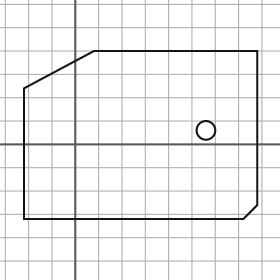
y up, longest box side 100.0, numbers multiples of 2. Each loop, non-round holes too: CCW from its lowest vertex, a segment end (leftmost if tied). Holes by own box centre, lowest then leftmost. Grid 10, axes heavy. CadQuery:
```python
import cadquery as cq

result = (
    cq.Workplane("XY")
    .moveTo(-22.0, -32.0)
    .lineTo(72.0, -32.0)
    .lineTo(78.0, -26.0)
    .lineTo(78.0, 40.0)
    .lineTo(8.0, 40.0)
    .lineTo(-22.0, 24.0)
    .close()
    .moveTo(56.0, 6.0)
    .circle(4.0)
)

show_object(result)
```